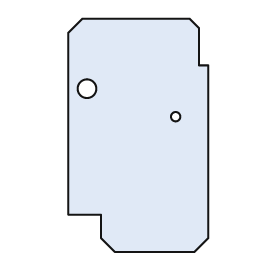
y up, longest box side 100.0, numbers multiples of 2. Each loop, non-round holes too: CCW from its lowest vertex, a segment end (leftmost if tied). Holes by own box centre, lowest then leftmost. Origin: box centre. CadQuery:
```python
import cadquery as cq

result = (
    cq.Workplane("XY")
    .moveTo(-10.0, -50.0)
    .lineTo(24.0, -50.0)
    .lineTo(30.0, -44.0)
    .lineTo(30.0, 30.0)
    .lineTo(26.0, 30.0)
    .lineTo(26.0, 46.0)
    .lineTo(22.0, 50.0)
    .lineTo(-24.0, 50.0)
    .lineTo(-30.0, 44.0)
    .lineTo(-30.0, -34.0)
    .lineTo(-16.0, -34.0)
    .lineTo(-16.0, -44.0)
    .close()
    .moveTo(16.0, 8.0)
    .circle(2.0)
    .moveTo(-22.0, 20.0)
    .circle(4.0)
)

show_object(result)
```